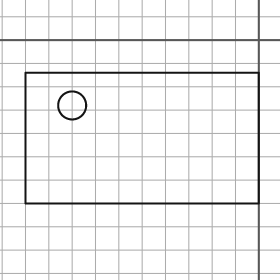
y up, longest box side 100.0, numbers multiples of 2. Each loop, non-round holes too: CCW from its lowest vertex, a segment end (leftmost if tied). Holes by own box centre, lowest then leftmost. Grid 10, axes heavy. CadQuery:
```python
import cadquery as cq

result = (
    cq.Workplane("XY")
    .moveTo(-100.0, -70.0)
    .lineTo(0.0, -70.0)
    .lineTo(0.0, -14.0)
    .lineTo(-100.0, -14.0)
    .close()
    .moveTo(-80.0, -28.0)
    .circle(6.0)
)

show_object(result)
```